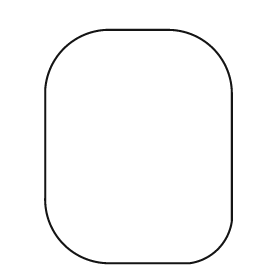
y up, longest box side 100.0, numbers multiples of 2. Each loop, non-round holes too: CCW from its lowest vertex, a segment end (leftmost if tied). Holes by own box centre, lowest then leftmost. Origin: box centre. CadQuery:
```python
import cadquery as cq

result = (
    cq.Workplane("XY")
    .moveTo(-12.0, -50.0)
    .lineTo(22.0, -50.0)
    .threePointArc((34.0, -44.0), (40.0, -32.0))
    .lineTo(40.0, 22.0)
    .threePointArc((32.0, 42.0), (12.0, 50.0))
    .lineTo(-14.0, 50.0)
    .threePointArc((-32.0, 42.0), (-40.0, 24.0))
    .lineTo(-40.0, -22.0)
    .threePointArc((-32.0, -42.0), (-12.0, -50.0))
    .close()
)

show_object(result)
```